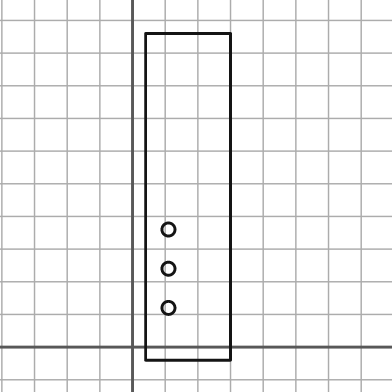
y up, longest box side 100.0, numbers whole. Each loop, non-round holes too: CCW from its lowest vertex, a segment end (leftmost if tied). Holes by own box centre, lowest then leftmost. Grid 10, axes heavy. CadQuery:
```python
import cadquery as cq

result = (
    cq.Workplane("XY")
    .moveTo(4.0, -4.0)
    .lineTo(30.0, -4.0)
    .lineTo(30.0, 96.0)
    .lineTo(4.0, 96.0)
    .close()
    .moveTo(11.0, 12.0)
    .circle(2.0)
    .moveTo(11.0, 24.0)
    .circle(2.0)
    .moveTo(11.0, 36.0)
    .circle(2.0)
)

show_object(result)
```